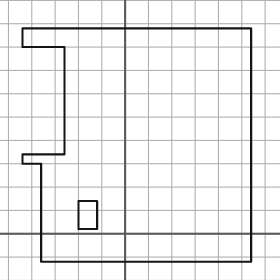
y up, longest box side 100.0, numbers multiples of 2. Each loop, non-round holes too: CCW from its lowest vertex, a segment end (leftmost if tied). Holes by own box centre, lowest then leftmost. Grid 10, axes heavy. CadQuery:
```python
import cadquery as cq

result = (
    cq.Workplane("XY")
    .moveTo(-36.0, -12.0)
    .lineTo(54.0, -12.0)
    .lineTo(54.0, 88.0)
    .lineTo(-44.0, 88.0)
    .lineTo(-44.0, 80.0)
    .lineTo(-26.0, 80.0)
    .lineTo(-26.0, 34.0)
    .lineTo(-44.0, 34.0)
    .lineTo(-44.0, 30.0)
    .lineTo(-36.0, 30.0)
    .close()
    .moveTo(-20.0, 2.0)
    .lineTo(-12.0, 2.0)
    .lineTo(-12.0, 14.0)
    .lineTo(-20.0, 14.0)
    .close()
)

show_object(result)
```